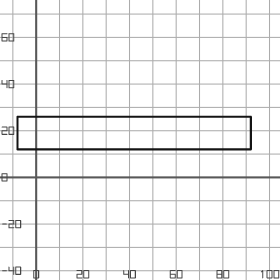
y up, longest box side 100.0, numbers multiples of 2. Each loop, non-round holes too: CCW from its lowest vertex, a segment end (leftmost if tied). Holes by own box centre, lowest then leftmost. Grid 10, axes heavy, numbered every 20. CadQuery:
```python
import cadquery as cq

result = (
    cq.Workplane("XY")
    .moveTo(-8.0, 12.0)
    .lineTo(92.0, 12.0)
    .lineTo(92.0, 26.0)
    .lineTo(-8.0, 26.0)
    .close()
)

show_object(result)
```